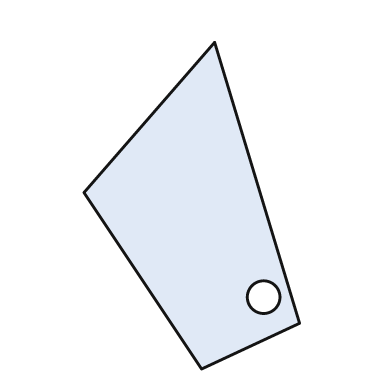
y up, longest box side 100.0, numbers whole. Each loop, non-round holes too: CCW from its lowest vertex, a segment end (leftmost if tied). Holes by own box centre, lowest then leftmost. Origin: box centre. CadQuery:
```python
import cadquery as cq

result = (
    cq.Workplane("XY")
    .moveTo(3.0, -50.0)
    .lineTo(33.0, -36.0)
    .lineTo(7.0, 50.0)
    .lineTo(-33.0, 4.0)
    .close()
    .moveTo(22.0, -28.0)
    .circle(5.0)
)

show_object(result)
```